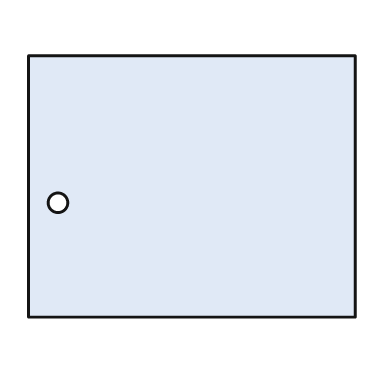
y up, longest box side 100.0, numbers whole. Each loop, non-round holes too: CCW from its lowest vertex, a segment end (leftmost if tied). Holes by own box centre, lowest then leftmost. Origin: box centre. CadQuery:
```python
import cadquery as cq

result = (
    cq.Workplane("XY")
    .moveTo(-50.0, -40.0)
    .lineTo(50.0, -40.0)
    .lineTo(50.0, 40.0)
    .lineTo(-50.0, 40.0)
    .close()
    .moveTo(-41.0, -5.0)
    .circle(3.0)
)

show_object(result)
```